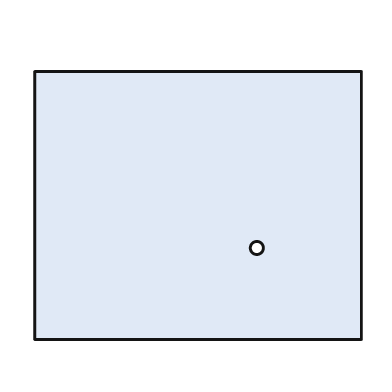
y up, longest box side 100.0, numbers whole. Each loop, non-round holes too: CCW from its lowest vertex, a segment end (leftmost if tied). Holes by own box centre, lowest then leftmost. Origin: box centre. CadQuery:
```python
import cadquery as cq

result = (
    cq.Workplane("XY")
    .moveTo(-50.0, -41.0)
    .lineTo(50.0, -41.0)
    .lineTo(50.0, 41.0)
    .lineTo(-50.0, 41.0)
    .close()
    .moveTo(18.0, -13.0)
    .circle(2.0)
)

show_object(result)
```